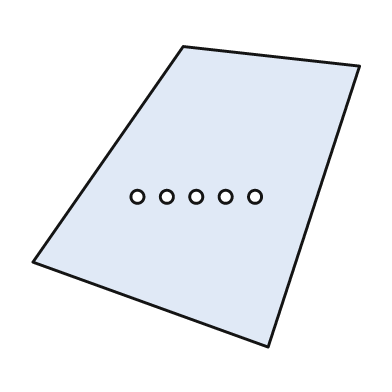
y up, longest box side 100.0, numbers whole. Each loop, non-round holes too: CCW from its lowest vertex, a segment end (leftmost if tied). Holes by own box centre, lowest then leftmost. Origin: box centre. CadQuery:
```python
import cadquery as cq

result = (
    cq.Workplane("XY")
    .moveTo(22.0, -46.0)
    .lineTo(50.0, 40.0)
    .lineTo(-4.0, 46.0)
    .lineTo(-50.0, -20.0)
    .close()
    .moveTo(-18.0, 0.0)
    .circle(2.0)
    .moveTo(-9.0, 0.0)
    .circle(2.0)
    .moveTo(0.0, 0.0)
    .circle(2.0)
    .moveTo(9.0, 0.0)
    .circle(2.0)
    .moveTo(18.0, 0.0)
    .circle(2.0)
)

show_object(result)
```